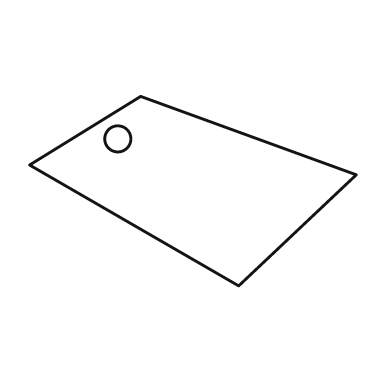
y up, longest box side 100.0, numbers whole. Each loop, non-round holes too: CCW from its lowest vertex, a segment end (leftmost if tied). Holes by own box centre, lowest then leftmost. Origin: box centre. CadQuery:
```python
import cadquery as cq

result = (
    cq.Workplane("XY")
    .moveTo(14.0, -29.0)
    .lineTo(50.0, 5.0)
    .lineTo(-16.0, 29.0)
    .lineTo(-50.0, 8.0)
    .close()
    .moveTo(-23.0, 16.0)
    .circle(4.0)
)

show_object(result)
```